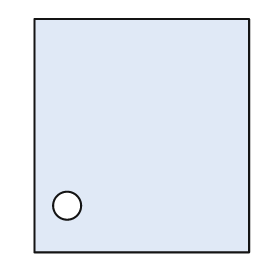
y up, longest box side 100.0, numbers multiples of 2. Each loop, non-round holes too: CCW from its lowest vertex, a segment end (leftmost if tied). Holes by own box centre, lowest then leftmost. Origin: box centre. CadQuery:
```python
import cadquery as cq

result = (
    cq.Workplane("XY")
    .moveTo(-46.0, -50.0)
    .lineTo(46.0, -50.0)
    .lineTo(46.0, 50.0)
    .lineTo(-46.0, 50.0)
    .close()
    .moveTo(-32.0, -30.0)
    .circle(6.0)
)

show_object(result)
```